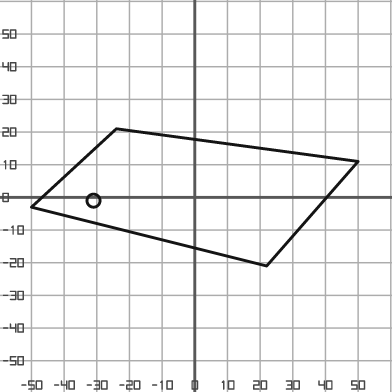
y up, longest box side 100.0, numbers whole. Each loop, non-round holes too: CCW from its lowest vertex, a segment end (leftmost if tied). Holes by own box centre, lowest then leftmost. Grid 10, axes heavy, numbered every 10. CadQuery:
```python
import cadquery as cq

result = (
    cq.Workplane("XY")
    .moveTo(22.0, -21.0)
    .lineTo(50.0, 11.0)
    .lineTo(-24.0, 21.0)
    .lineTo(-50.0, -3.0)
    .close()
    .moveTo(-31.0, -1.0)
    .circle(2.0)
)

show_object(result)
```